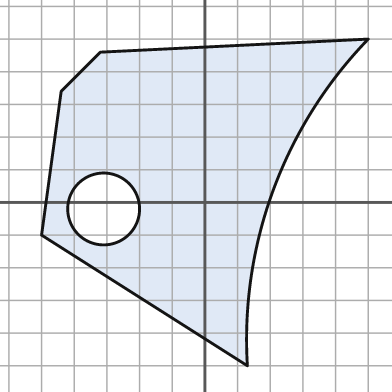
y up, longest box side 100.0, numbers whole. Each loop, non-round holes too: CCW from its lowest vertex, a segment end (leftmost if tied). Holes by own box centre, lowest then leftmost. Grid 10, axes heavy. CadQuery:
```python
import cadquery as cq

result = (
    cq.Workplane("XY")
    .moveTo(13.0, -50.0)
    .threePointArc((21.0, 4.0), (50.0, 50.0))
    .lineTo(-32.0, 46.0)
    .lineTo(-44.0, 34.0)
    .lineTo(-50.0, -10.0)
    .close()
    .moveTo(-31.0, -2.0)
    .circle(11.0)
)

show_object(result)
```